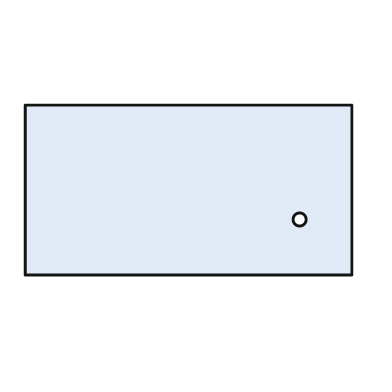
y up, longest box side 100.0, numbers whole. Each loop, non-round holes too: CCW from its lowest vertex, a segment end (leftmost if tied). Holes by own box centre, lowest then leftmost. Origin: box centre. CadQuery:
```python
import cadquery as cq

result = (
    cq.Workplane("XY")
    .moveTo(-50.0, -26.0)
    .lineTo(50.0, -26.0)
    .lineTo(50.0, 26.0)
    .lineTo(-50.0, 26.0)
    .close()
    .moveTo(34.0, -9.0)
    .circle(2.0)
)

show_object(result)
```